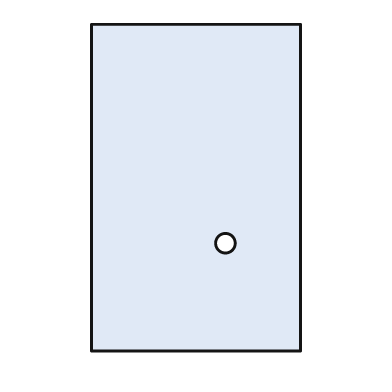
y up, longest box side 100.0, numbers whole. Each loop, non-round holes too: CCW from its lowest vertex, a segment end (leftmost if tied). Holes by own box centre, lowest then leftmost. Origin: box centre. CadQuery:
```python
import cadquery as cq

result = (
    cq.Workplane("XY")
    .moveTo(-32.0, -50.0)
    .lineTo(32.0, -50.0)
    .lineTo(32.0, 50.0)
    .lineTo(-32.0, 50.0)
    .close()
    .moveTo(9.0, -17.0)
    .circle(3.0)
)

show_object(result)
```